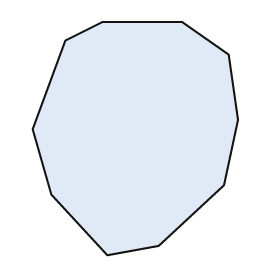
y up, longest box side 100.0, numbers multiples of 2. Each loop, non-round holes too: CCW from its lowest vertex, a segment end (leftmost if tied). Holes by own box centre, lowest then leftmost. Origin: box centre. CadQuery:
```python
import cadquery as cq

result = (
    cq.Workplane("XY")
    .moveTo(-12.0, -50.0)
    .lineTo(10.0, -46.0)
    .lineTo(38.0, -20.0)
    .lineTo(44.0, 8.0)
    .lineTo(40.0, 36.0)
    .lineTo(20.0, 50.0)
    .lineTo(-14.0, 50.0)
    .lineTo(-30.0, 42.0)
    .lineTo(-44.0, 4.0)
    .lineTo(-36.0, -24.0)
    .close()
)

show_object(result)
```